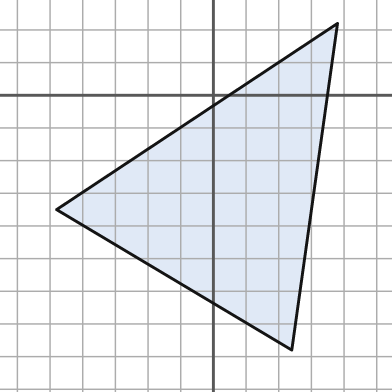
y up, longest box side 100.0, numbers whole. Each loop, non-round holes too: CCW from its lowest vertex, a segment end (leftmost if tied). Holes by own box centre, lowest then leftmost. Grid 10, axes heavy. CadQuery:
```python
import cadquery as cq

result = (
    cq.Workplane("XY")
    .moveTo(24.0, -78.0)
    .lineTo(38.0, 22.0)
    .lineTo(-48.0, -35.0)
    .close()
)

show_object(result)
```